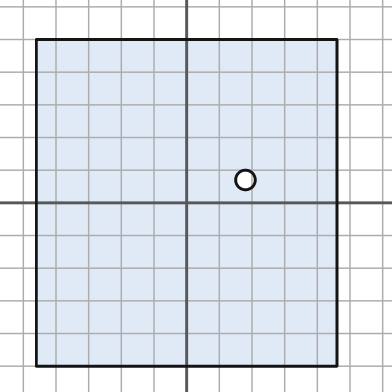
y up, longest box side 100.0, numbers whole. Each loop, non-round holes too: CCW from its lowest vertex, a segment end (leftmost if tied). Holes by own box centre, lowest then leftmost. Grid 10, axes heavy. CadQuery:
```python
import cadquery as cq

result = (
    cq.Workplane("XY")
    .moveTo(-46.0, -50.0)
    .lineTo(46.0, -50.0)
    .lineTo(46.0, 50.0)
    .lineTo(-46.0, 50.0)
    .close()
    .moveTo(18.0, 7.0)
    .circle(3.0)
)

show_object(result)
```